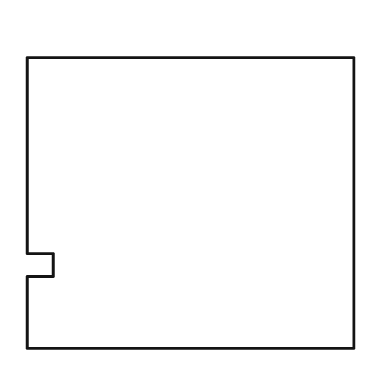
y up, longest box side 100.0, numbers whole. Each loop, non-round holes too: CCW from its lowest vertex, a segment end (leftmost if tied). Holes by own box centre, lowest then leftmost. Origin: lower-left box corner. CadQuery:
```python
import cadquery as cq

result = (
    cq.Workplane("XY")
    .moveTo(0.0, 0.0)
    .lineTo(100.0, 0.0)
    .lineTo(100.0, 89.0)
    .lineTo(0.0, 89.0)
    .lineTo(0.0, 29.0)
    .lineTo(8.0, 29.0)
    .lineTo(8.0, 22.0)
    .lineTo(0.0, 22.0)
    .close()
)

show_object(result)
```